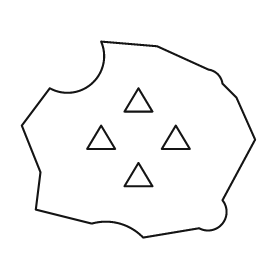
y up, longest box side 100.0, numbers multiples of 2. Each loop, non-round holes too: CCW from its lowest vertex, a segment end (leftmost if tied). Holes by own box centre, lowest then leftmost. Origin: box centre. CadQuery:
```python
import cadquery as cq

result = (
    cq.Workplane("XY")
    .moveTo(2.0, -42.0)
    .lineTo(26.0, -38.0)
    .threePointArc((36.0, -36.0), (36.0, -26.0))
    .lineTo(50.0, 0.0)
    .lineTo(42.0, 18.0)
    .lineTo(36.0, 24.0)
    .threePointArc((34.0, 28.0), (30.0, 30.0))
    .lineTo(8.0, 40.0)
    .lineTo(-16.0, 42.0)
    .threePointArc((-20.0, 24.0), (-38.0, 22.0))
    .lineTo(-50.0, 6.0)
    .lineTo(-42.0, -14.0)
    .lineTo(-44.0, -30.0)
    .lineTo(-20.0, -36.0)
    .threePointArc((-8.0, -36.0), (2.0, -42.0))
    .close()
    .moveTo(-6.0, -20.0)
    .lineTo(6.0, -20.0)
    .lineTo(0.0, -10.0)
    .close()
    .moveTo(-22.0, -4.0)
    .lineTo(-10.0, -4.0)
    .lineTo(-16.0, 6.0)
    .close()
    .moveTo(10.0, -4.0)
    .lineTo(22.0, -4.0)
    .lineTo(16.0, 6.0)
    .close()
    .moveTo(-6.0, 12.0)
    .lineTo(6.0, 12.0)
    .lineTo(0.0, 22.0)
    .close()
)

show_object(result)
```